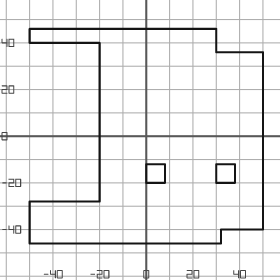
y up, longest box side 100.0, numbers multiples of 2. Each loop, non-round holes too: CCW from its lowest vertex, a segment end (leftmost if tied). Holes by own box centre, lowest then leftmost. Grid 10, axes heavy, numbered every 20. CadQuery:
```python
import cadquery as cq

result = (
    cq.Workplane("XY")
    .moveTo(-50.0, -46.0)
    .lineTo(32.0, -46.0)
    .lineTo(32.0, -40.0)
    .lineTo(50.0, -40.0)
    .lineTo(50.0, 36.0)
    .lineTo(30.0, 36.0)
    .lineTo(30.0, 46.0)
    .lineTo(-50.0, 46.0)
    .lineTo(-50.0, 40.0)
    .lineTo(-20.0, 40.0)
    .lineTo(-20.0, -28.0)
    .lineTo(-50.0, -28.0)
    .close()
    .moveTo(0.0, -20.0)
    .lineTo(8.0, -20.0)
    .lineTo(8.0, -12.0)
    .lineTo(0.0, -12.0)
    .close()
    .moveTo(30.0, -20.0)
    .lineTo(38.0, -20.0)
    .lineTo(38.0, -12.0)
    .lineTo(30.0, -12.0)
    .close()
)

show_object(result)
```